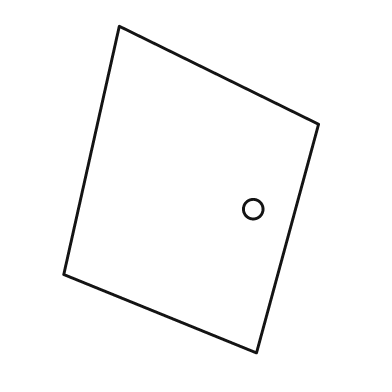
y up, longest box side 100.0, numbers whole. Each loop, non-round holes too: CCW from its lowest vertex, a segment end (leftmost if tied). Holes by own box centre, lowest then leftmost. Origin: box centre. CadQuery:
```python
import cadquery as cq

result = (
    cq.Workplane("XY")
    .moveTo(20.0, -50.0)
    .lineTo(39.0, 20.0)
    .lineTo(-22.0, 50.0)
    .lineTo(-39.0, -26.0)
    .close()
    .moveTo(19.0, -6.0)
    .circle(3.0)
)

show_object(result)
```